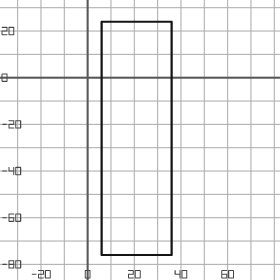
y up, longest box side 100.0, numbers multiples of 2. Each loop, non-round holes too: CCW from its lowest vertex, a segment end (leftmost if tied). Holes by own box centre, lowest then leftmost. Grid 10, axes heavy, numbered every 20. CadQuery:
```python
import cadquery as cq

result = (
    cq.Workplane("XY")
    .moveTo(6.0, -76.0)
    .lineTo(36.0, -76.0)
    .lineTo(36.0, 24.0)
    .lineTo(6.0, 24.0)
    .close()
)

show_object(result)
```